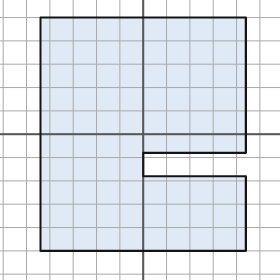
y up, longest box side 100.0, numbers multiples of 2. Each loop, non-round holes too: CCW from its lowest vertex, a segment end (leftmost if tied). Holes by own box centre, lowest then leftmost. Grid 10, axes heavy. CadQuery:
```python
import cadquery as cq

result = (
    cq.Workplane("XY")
    .moveTo(-44.0, -50.0)
    .lineTo(44.0, -50.0)
    .lineTo(44.0, -18.0)
    .lineTo(0.0, -18.0)
    .lineTo(0.0, -8.0)
    .lineTo(44.0, -8.0)
    .lineTo(44.0, 50.0)
    .lineTo(-44.0, 50.0)
    .close()
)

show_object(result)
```